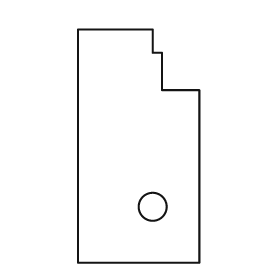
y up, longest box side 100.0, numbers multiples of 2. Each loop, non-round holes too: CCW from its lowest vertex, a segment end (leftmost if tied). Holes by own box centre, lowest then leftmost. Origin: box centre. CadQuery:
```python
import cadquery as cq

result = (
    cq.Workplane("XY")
    .moveTo(-26.0, -50.0)
    .lineTo(26.0, -50.0)
    .lineTo(26.0, 24.0)
    .lineTo(10.0, 24.0)
    .lineTo(10.0, 40.0)
    .lineTo(6.0, 40.0)
    .lineTo(6.0, 50.0)
    .lineTo(-26.0, 50.0)
    .close()
    .moveTo(6.0, -26.0)
    .circle(6.0)
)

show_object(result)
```